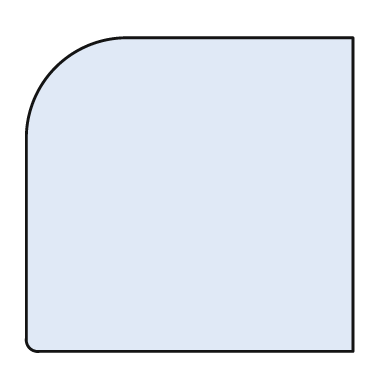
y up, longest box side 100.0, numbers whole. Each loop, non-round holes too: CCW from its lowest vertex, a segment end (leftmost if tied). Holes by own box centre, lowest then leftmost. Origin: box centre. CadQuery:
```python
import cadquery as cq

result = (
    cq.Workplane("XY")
    .moveTo(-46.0, -48.0)
    .lineTo(50.0, -48.0)
    .lineTo(50.0, 48.0)
    .lineTo(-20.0, 48.0)
    .threePointArc((-41.0, 39.0), (-50.0, 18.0))
    .lineTo(-50.0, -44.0)
    .threePointArc((-49.0, -47.0), (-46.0, -48.0))
    .close()
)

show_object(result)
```